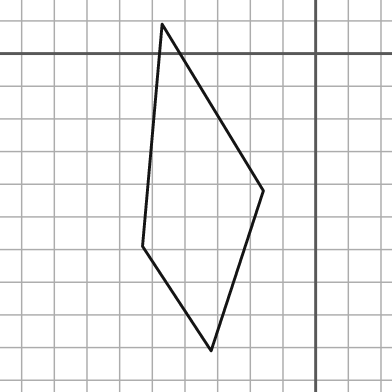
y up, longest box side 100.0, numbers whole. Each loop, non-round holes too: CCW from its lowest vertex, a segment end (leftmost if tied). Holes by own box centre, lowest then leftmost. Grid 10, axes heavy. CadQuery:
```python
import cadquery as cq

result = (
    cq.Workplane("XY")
    .moveTo(-32.0, -91.0)
    .lineTo(-16.0, -42.0)
    .lineTo(-47.0, 9.0)
    .lineTo(-53.0, -59.0)
    .close()
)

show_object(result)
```